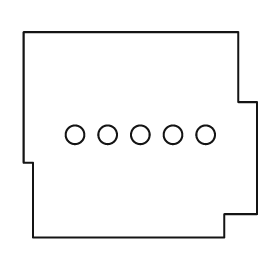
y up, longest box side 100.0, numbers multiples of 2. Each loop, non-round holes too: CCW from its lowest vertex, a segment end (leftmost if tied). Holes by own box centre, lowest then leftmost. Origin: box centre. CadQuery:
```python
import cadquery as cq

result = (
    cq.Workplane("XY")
    .moveTo(-46.0, -44.0)
    .lineTo(36.0, -44.0)
    .lineTo(36.0, -34.0)
    .lineTo(50.0, -34.0)
    .lineTo(50.0, 14.0)
    .lineTo(42.0, 14.0)
    .lineTo(42.0, 44.0)
    .lineTo(-50.0, 44.0)
    .lineTo(-50.0, -12.0)
    .lineTo(-46.0, -12.0)
    .close()
    .moveTo(-28.0, 0.0)
    .circle(4.0)
    .moveTo(-14.0, 0.0)
    .circle(4.0)
    .moveTo(0.0, 0.0)
    .circle(4.0)
    .moveTo(14.0, 0.0)
    .circle(4.0)
    .moveTo(28.0, 0.0)
    .circle(4.0)
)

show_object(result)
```